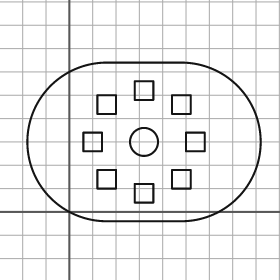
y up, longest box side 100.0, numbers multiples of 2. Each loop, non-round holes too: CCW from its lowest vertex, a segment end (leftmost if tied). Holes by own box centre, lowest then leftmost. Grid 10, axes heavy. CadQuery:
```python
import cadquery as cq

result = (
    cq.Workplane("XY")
    .moveTo(16.0, -4.0)
    .lineTo(48.0, -4.0)
    .threePointArc((82.0, 30.0), (48.0, 64.0))
    .lineTo(16.0, 64.0)
    .threePointArc((-18.0, 30.0), (16.0, -4.0))
    .close()
    .moveTo(28.0, 4.0)
    .lineTo(36.0, 4.0)
    .lineTo(36.0, 12.0)
    .lineTo(28.0, 12.0)
    .close()
    .moveTo(12.0, 10.0)
    .lineTo(20.0, 10.0)
    .lineTo(20.0, 18.0)
    .lineTo(12.0, 18.0)
    .close()
    .moveTo(44.0, 10.0)
    .lineTo(52.0, 10.0)
    .lineTo(52.0, 18.0)
    .lineTo(44.0, 18.0)
    .close()
    .moveTo(6.0, 26.0)
    .lineTo(14.0, 26.0)
    .lineTo(14.0, 34.0)
    .lineTo(6.0, 34.0)
    .close()
    .moveTo(32.0, 30.0)
    .circle(6.0)
    .moveTo(50.0, 26.0)
    .lineTo(58.0, 26.0)
    .lineTo(58.0, 34.0)
    .lineTo(50.0, 34.0)
    .close()
    .moveTo(12.0, 42.0)
    .lineTo(20.0, 42.0)
    .lineTo(20.0, 50.0)
    .lineTo(12.0, 50.0)
    .close()
    .moveTo(44.0, 42.0)
    .lineTo(52.0, 42.0)
    .lineTo(52.0, 50.0)
    .lineTo(44.0, 50.0)
    .close()
    .moveTo(28.0, 48.0)
    .lineTo(36.0, 48.0)
    .lineTo(36.0, 56.0)
    .lineTo(28.0, 56.0)
    .close()
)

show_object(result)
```